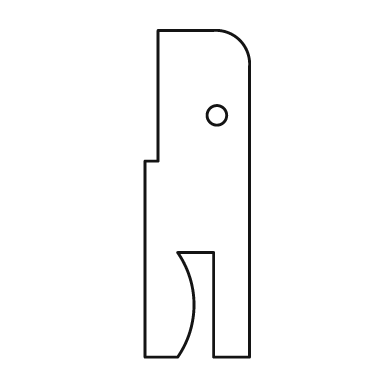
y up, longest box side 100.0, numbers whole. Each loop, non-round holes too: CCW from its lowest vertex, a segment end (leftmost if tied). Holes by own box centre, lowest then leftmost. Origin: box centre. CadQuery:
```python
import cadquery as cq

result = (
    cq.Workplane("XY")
    .moveTo(-16.0, -50.0)
    .lineTo(-6.0, -50.0)
    .threePointArc((-1.0, -34.0), (-6.0, -18.0))
    .lineTo(5.0, -18.0)
    .lineTo(5.0, -50.0)
    .lineTo(16.0, -50.0)
    .lineTo(16.0, 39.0)
    .threePointArc((13.0, 47.0), (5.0, 50.0))
    .lineTo(-12.0, 50.0)
    .lineTo(-12.0, 10.0)
    .lineTo(-16.0, 10.0)
    .close()
    .moveTo(6.0, 24.0)
    .circle(3.0)
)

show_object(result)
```